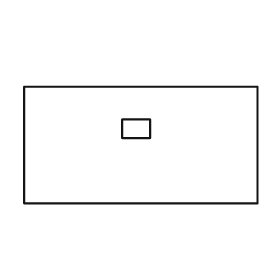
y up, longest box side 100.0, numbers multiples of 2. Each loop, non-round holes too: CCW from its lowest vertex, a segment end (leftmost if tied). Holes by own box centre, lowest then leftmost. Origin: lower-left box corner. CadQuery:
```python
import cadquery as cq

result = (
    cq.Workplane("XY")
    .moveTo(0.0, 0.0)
    .lineTo(100.0, 0.0)
    .lineTo(100.0, 50.0)
    .lineTo(0.0, 50.0)
    .close()
    .moveTo(42.0, 28.0)
    .lineTo(54.0, 28.0)
    .lineTo(54.0, 36.0)
    .lineTo(42.0, 36.0)
    .close()
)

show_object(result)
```